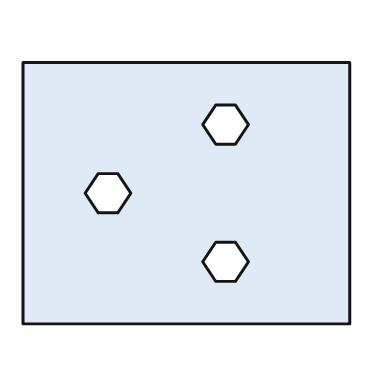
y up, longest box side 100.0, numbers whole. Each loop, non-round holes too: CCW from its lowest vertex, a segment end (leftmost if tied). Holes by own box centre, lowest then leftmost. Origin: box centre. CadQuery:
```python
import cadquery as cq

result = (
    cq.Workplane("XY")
    .moveTo(-50.0, -40.0)
    .lineTo(50.0, -40.0)
    .lineTo(50.0, 40.0)
    .lineTo(-50.0, 40.0)
    .close()
    .moveTo(9.0, -27.0)
    .lineTo(15.0, -27.0)
    .lineTo(19.0, -21.0)
    .lineTo(15.0, -15.0)
    .lineTo(9.0, -15.0)
    .lineTo(5.0, -21.0)
    .close()
    .moveTo(-27.0, -6.0)
    .lineTo(-21.0, -6.0)
    .lineTo(-17.0, 0.0)
    .lineTo(-21.0, 6.0)
    .lineTo(-27.0, 6.0)
    .lineTo(-31.0, 0.0)
    .close()
    .moveTo(9.0, 15.0)
    .lineTo(15.0, 15.0)
    .lineTo(19.0, 21.0)
    .lineTo(15.0, 27.0)
    .lineTo(9.0, 27.0)
    .lineTo(5.0, 21.0)
    .close()
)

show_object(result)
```